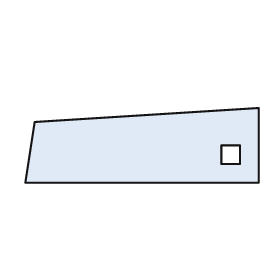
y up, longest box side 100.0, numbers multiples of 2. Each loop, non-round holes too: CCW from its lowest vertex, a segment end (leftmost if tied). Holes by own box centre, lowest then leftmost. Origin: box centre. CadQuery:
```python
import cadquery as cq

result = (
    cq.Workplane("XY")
    .moveTo(-50.0, -16.0)
    .lineTo(50.0, -16.0)
    .lineTo(50.0, 16.0)
    .lineTo(-46.0, 10.0)
    .close()
    .moveTo(34.0, -8.0)
    .lineTo(42.0, -8.0)
    .lineTo(42.0, 0.0)
    .lineTo(34.0, 0.0)
    .close()
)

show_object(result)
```